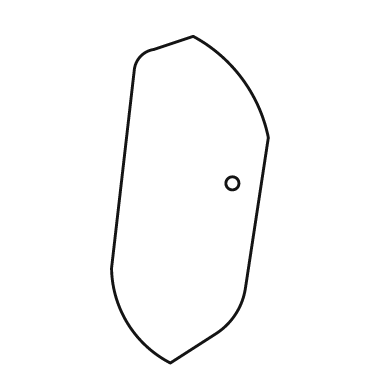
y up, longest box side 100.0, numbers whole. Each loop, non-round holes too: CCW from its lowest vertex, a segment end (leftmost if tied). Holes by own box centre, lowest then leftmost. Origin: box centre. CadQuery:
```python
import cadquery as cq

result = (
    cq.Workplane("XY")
    .moveTo(-6.0, -50.0)
    .lineTo(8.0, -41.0)
    .threePointArc((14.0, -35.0), (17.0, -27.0))
    .lineTo(24.0, 19.0)
    .threePointArc((16.0, 37.0), (1.0, 50.0))
    .lineTo(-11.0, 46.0)
    .threePointArc((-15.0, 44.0), (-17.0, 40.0))
    .lineTo(-24.0, -21.0)
    .threePointArc((-19.0, -38.0), (-6.0, -50.0))
    .close()
    .moveTo(13.0, 5.0)
    .circle(2.0)
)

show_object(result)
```